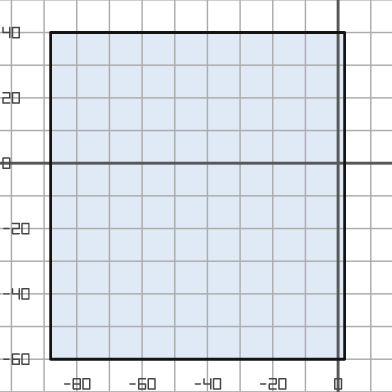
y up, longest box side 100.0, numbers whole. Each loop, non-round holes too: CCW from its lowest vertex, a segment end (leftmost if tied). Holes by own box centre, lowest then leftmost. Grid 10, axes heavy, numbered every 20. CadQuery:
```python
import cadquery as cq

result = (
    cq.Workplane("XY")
    .moveTo(-88.0, -60.0)
    .lineTo(2.0, -60.0)
    .lineTo(2.0, 40.0)
    .lineTo(-88.0, 40.0)
    .close()
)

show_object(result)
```